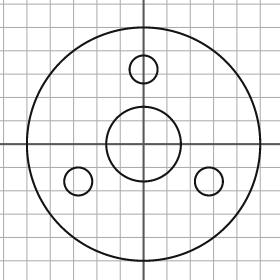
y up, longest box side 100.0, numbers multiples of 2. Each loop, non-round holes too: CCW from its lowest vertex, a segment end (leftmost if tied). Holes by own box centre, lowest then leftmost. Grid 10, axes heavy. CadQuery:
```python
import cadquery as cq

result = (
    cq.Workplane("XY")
    .moveTo(0.0, 0.0)
    .circle(50.0)
    .moveTo(-28.0, -16.0)
    .circle(6.0)
    .moveTo(28.0, -16.0)
    .circle(6.0)
    .moveTo(0.0, 0.0)
    .circle(16.0)
    .moveTo(0.0, 32.0)
    .circle(6.0)
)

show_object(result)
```